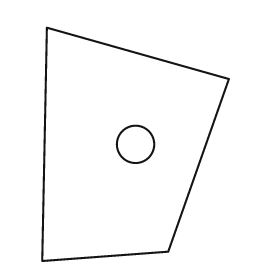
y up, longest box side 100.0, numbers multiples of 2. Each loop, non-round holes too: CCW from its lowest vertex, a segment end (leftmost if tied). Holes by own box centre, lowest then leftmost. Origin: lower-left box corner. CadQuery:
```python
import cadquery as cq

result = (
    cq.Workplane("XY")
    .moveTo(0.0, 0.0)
    .lineTo(54.0, 4.0)
    .lineTo(80.0, 78.0)
    .lineTo(2.0, 100.0)
    .close()
    .moveTo(40.0, 50.0)
    .circle(8.0)
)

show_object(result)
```